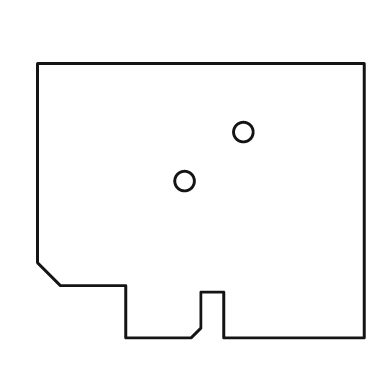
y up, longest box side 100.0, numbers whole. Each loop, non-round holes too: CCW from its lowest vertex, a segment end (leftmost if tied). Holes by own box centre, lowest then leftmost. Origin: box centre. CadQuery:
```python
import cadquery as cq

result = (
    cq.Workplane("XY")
    .moveTo(-23.0, -42.0)
    .lineTo(-3.0, -42.0)
    .lineTo(0.0, -39.0)
    .lineTo(0.0, -28.0)
    .lineTo(7.0, -28.0)
    .lineTo(7.0, -42.0)
    .lineTo(50.0, -42.0)
    .lineTo(50.0, 42.0)
    .lineTo(-50.0, 42.0)
    .lineTo(-50.0, -19.0)
    .lineTo(-43.0, -26.0)
    .lineTo(-23.0, -26.0)
    .close()
    .moveTo(-5.0, 6.0)
    .circle(3.0)
    .moveTo(13.0, 21.0)
    .circle(3.0)
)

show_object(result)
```